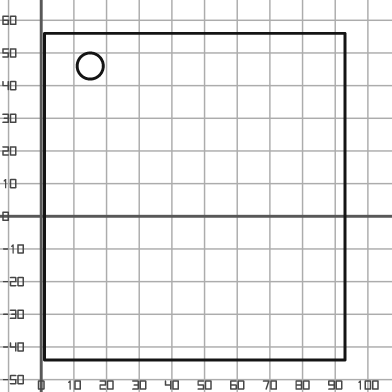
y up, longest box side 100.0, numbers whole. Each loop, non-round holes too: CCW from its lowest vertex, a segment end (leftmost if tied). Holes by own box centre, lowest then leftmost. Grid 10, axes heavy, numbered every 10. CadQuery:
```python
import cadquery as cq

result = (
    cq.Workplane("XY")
    .moveTo(1.0, -44.0)
    .lineTo(93.0, -44.0)
    .lineTo(93.0, 56.0)
    .lineTo(1.0, 56.0)
    .close()
    .moveTo(15.0, 46.0)
    .circle(4.0)
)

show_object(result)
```